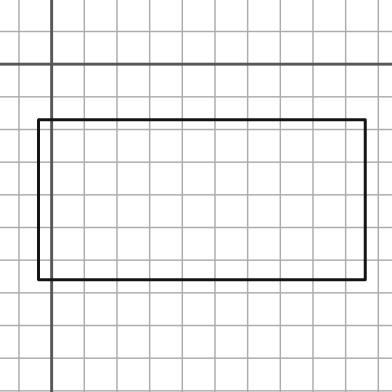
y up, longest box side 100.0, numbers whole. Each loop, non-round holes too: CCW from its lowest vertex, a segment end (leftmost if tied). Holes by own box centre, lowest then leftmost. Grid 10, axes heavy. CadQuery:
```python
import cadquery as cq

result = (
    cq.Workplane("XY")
    .moveTo(-4.0, -66.0)
    .lineTo(96.0, -66.0)
    .lineTo(96.0, -17.0)
    .lineTo(-4.0, -17.0)
    .close()
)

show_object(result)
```